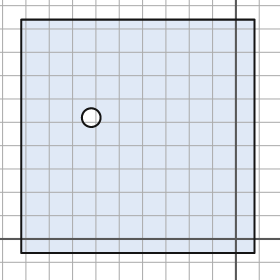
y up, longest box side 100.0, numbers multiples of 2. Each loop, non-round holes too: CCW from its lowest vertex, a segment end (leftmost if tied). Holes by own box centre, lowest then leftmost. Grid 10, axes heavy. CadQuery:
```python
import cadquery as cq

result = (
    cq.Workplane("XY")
    .moveTo(-92.0, -6.0)
    .lineTo(8.0, -6.0)
    .lineTo(8.0, 94.0)
    .lineTo(-92.0, 94.0)
    .close()
    .moveTo(-62.0, 52.0)
    .circle(4.0)
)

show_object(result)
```